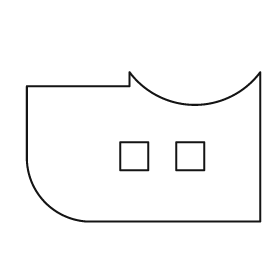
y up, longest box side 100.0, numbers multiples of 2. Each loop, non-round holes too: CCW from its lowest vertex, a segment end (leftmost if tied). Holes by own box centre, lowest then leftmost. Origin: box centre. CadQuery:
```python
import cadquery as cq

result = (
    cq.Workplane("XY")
    .moveTo(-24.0, -32.0)
    .lineTo(50.0, -32.0)
    .lineTo(50.0, 32.0)
    .threePointArc((22.0, 18.0), (-6.0, 32.0))
    .lineTo(-6.0, 26.0)
    .lineTo(-50.0, 26.0)
    .lineTo(-50.0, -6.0)
    .threePointArc((-42.0, -24.0), (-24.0, -32.0))
    .close()
    .moveTo(-10.0, -10.0)
    .lineTo(2.0, -10.0)
    .lineTo(2.0, 2.0)
    .lineTo(-10.0, 2.0)
    .close()
    .moveTo(14.0, -10.0)
    .lineTo(26.0, -10.0)
    .lineTo(26.0, 2.0)
    .lineTo(14.0, 2.0)
    .close()
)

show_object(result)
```